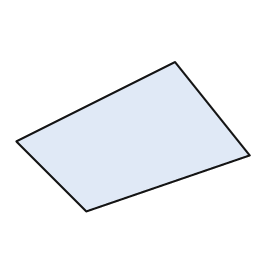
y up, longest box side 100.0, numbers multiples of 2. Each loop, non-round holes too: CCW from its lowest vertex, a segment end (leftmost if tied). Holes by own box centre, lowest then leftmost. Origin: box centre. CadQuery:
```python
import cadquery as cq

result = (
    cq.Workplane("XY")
    .moveTo(-20.0, -32.0)
    .lineTo(50.0, -8.0)
    .lineTo(18.0, 32.0)
    .lineTo(-50.0, -2.0)
    .close()
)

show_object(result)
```